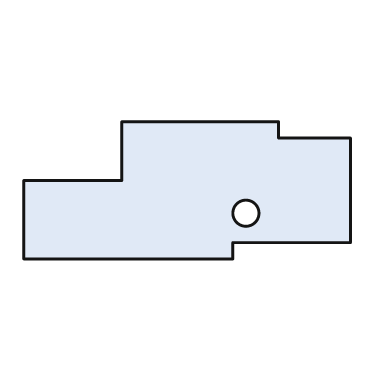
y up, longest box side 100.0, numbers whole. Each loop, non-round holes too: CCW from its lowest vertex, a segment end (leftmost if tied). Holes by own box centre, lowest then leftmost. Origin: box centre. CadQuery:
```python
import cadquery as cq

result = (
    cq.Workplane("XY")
    .moveTo(-50.0, -21.0)
    .lineTo(14.0, -21.0)
    .lineTo(14.0, -16.0)
    .lineTo(50.0, -16.0)
    .lineTo(50.0, 16.0)
    .lineTo(28.0, 16.0)
    .lineTo(28.0, 21.0)
    .lineTo(-20.0, 21.0)
    .lineTo(-20.0, 3.0)
    .lineTo(-50.0, 3.0)
    .close()
    .moveTo(18.0, -7.0)
    .circle(4.0)
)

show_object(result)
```